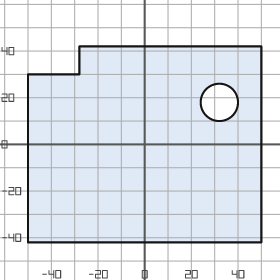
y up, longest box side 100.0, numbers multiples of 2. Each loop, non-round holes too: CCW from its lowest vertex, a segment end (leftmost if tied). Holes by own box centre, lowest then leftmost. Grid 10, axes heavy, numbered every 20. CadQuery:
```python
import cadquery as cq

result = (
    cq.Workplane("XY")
    .moveTo(-50.0, -42.0)
    .lineTo(50.0, -42.0)
    .lineTo(50.0, 42.0)
    .lineTo(-28.0, 42.0)
    .lineTo(-28.0, 30.0)
    .lineTo(-50.0, 30.0)
    .close()
    .moveTo(32.0, 18.0)
    .circle(8.0)
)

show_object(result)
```